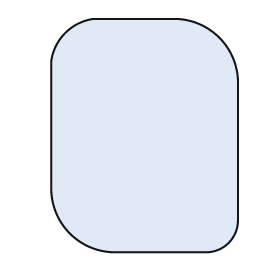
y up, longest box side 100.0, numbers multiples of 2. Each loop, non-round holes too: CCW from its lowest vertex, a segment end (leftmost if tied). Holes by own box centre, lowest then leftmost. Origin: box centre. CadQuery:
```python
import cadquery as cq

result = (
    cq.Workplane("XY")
    .moveTo(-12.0, -50.0)
    .lineTo(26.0, -50.0)
    .threePointArc((36.0, -46.0), (40.0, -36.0))
    .lineTo(40.0, 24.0)
    .threePointArc((32.0, 42.0), (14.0, 50.0))
    .lineTo(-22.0, 50.0)
    .threePointArc((-34.0, 44.0), (-40.0, 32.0))
    .lineTo(-40.0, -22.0)
    .threePointArc((-32.0, -42.0), (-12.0, -50.0))
    .close()
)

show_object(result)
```